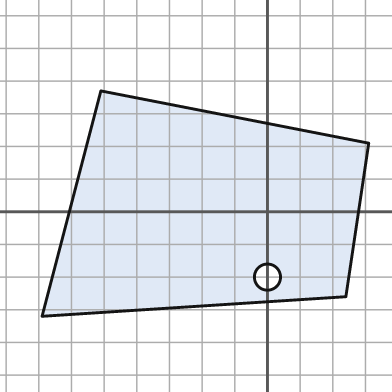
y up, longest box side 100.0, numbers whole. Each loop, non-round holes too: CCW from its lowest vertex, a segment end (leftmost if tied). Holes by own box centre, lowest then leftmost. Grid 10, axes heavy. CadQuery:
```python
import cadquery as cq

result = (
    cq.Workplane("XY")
    .moveTo(-69.0, -32.0)
    .lineTo(24.0, -26.0)
    .lineTo(31.0, 21.0)
    .lineTo(-51.0, 37.0)
    .close()
    .moveTo(0.0, -20.0)
    .circle(4.0)
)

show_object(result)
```